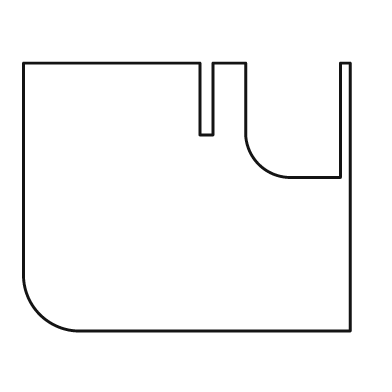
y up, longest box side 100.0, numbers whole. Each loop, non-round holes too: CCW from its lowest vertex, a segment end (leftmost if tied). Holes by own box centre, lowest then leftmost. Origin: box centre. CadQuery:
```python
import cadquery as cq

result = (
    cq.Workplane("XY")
    .moveTo(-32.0, -41.0)
    .lineTo(50.0, -41.0)
    .lineTo(50.0, 41.0)
    .lineTo(47.0, 41.0)
    .lineTo(47.0, 6.0)
    .lineTo(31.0, 6.0)
    .threePointArc((22.0, 10.0), (18.0, 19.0))
    .lineTo(18.0, 41.0)
    .lineTo(8.0, 41.0)
    .lineTo(8.0, 19.0)
    .lineTo(4.0, 19.0)
    .lineTo(4.0, 41.0)
    .lineTo(-50.0, 41.0)
    .lineTo(-50.0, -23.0)
    .threePointArc((-45.0, -36.0), (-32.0, -41.0))
    .close()
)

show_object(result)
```